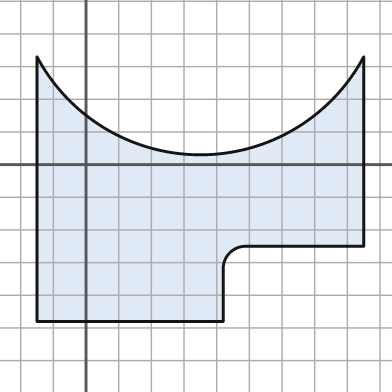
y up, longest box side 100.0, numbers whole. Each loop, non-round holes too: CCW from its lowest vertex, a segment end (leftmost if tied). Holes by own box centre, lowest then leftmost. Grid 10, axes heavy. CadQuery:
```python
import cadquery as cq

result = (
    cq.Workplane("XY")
    .moveTo(-15.0, -48.0)
    .lineTo(42.0, -48.0)
    .lineTo(42.0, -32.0)
    .threePointArc((44.0, -27.0), (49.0, -25.0))
    .lineTo(85.0, -25.0)
    .lineTo(85.0, 33.0)
    .threePointArc((35.0, 3.0), (-15.0, 33.0))
    .close()
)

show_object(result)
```